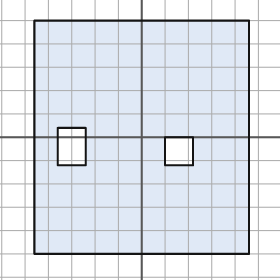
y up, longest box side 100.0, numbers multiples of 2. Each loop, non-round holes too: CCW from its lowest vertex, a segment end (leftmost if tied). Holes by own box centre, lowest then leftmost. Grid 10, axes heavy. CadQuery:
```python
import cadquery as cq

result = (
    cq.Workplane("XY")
    .moveTo(-46.0, -50.0)
    .lineTo(46.0, -50.0)
    .lineTo(46.0, 50.0)
    .lineTo(-46.0, 50.0)
    .close()
    .moveTo(10.0, -12.0)
    .lineTo(22.0, -12.0)
    .lineTo(22.0, 0.0)
    .lineTo(10.0, 0.0)
    .close()
    .moveTo(-36.0, -12.0)
    .lineTo(-24.0, -12.0)
    .lineTo(-24.0, 4.0)
    .lineTo(-36.0, 4.0)
    .close()
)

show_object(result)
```